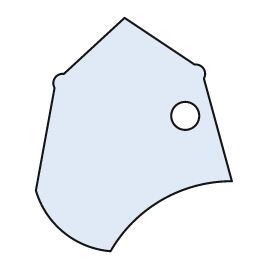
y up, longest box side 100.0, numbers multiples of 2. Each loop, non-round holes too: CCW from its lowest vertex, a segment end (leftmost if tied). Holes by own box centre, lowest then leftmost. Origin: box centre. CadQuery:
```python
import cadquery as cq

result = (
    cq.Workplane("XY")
    .moveTo(-10.0, -50.0)
    .threePointArc((12.0, -28.0), (42.0, -20.0))
    .lineTo(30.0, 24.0)
    .threePointArc((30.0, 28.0), (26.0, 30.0))
    .lineTo(-4.0, 50.0)
    .lineTo(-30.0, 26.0)
    .threePointArc((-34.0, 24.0), (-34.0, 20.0))
    .lineTo(-42.0, -24.0)
    .threePointArc((-30.0, -42.0), (-10.0, -50.0))
    .close()
    .moveTo(22.0, 8.0)
    .circle(6.0)
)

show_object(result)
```